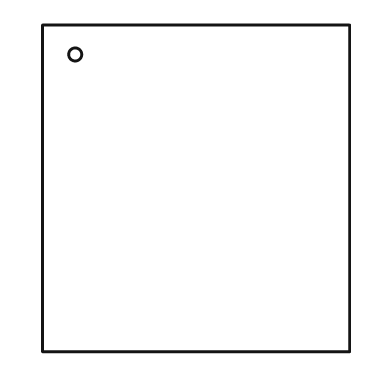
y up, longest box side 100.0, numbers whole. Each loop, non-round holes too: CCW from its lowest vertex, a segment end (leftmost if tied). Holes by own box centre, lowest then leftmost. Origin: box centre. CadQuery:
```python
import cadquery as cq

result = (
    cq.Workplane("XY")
    .moveTo(-47.0, -50.0)
    .lineTo(47.0, -50.0)
    .lineTo(47.0, 50.0)
    .lineTo(-47.0, 50.0)
    .close()
    .moveTo(-37.0, 41.0)
    .circle(2.0)
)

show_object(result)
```